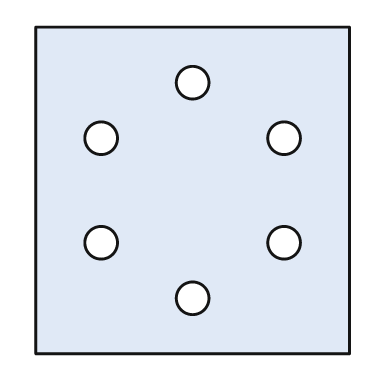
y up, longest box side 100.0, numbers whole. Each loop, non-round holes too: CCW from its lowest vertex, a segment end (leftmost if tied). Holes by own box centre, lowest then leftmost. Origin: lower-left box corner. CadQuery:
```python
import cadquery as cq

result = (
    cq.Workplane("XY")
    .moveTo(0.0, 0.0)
    .lineTo(96.0, 0.0)
    .lineTo(96.0, 100.0)
    .lineTo(0.0, 100.0)
    .close()
    .moveTo(48.0, 17.0)
    .circle(5.0)
    .moveTo(20.0, 34.0)
    .circle(5.0)
    .moveTo(76.0, 34.0)
    .circle(5.0)
    .moveTo(20.0, 66.0)
    .circle(5.0)
    .moveTo(76.0, 66.0)
    .circle(5.0)
    .moveTo(48.0, 83.0)
    .circle(5.0)
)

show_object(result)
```